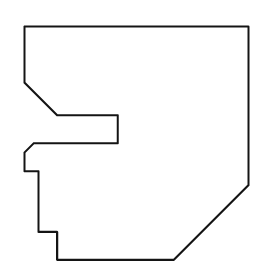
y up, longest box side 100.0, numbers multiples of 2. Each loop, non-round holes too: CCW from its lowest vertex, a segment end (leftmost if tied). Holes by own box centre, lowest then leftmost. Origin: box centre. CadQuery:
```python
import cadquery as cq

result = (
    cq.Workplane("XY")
    .moveTo(-34.0, -50.0)
    .lineTo(16.0, -50.0)
    .lineTo(48.0, -18.0)
    .lineTo(48.0, 50.0)
    .lineTo(-48.0, 50.0)
    .lineTo(-48.0, 26.0)
    .lineTo(-34.0, 12.0)
    .lineTo(-8.0, 12.0)
    .lineTo(-8.0, 0.0)
    .lineTo(-44.0, 0.0)
    .lineTo(-48.0, -4.0)
    .lineTo(-48.0, -12.0)
    .lineTo(-42.0, -12.0)
    .lineTo(-42.0, -38.0)
    .lineTo(-34.0, -38.0)
    .close()
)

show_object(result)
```